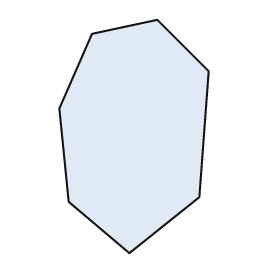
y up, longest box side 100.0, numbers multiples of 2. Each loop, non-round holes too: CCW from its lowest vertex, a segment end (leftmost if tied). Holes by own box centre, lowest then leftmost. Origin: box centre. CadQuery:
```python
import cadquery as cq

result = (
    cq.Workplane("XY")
    .moveTo(-2.0, -50.0)
    .lineTo(28.0, -26.0)
    .lineTo(32.0, 28.0)
    .lineTo(10.0, 50.0)
    .lineTo(-18.0, 44.0)
    .lineTo(-32.0, 12.0)
    .lineTo(-28.0, -28.0)
    .close()
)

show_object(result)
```